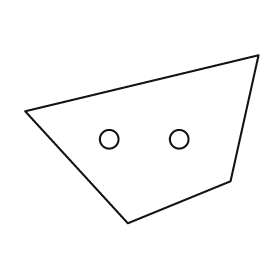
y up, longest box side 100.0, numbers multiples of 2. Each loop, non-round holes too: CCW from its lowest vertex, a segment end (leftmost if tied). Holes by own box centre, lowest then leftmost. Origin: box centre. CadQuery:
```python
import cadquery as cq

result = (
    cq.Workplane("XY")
    .moveTo(-6.0, -36.0)
    .lineTo(38.0, -18.0)
    .lineTo(50.0, 36.0)
    .lineTo(-50.0, 12.0)
    .close()
    .moveTo(-14.0, 0.0)
    .circle(4.0)
    .moveTo(16.0, 0.0)
    .circle(4.0)
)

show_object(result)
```